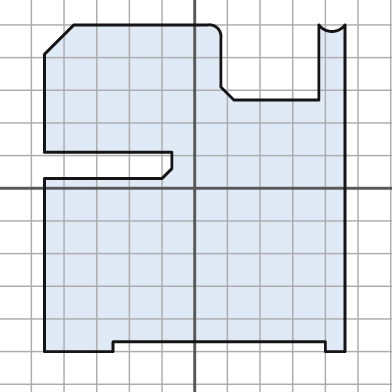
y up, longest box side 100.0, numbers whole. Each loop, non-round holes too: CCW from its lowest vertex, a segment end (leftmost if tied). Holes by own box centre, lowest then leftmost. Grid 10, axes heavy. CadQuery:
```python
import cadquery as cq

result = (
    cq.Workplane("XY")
    .moveTo(-46.0, -50.0)
    .lineTo(-25.0, -50.0)
    .lineTo(-25.0, -47.0)
    .lineTo(40.0, -47.0)
    .lineTo(40.0, -50.0)
    .lineTo(46.0, -50.0)
    .lineTo(46.0, 50.0)
    .threePointArc((42.0, 48.0), (38.0, 50.0))
    .lineTo(38.0, 27.0)
    .lineTo(12.0, 27.0)
    .lineTo(8.0, 31.0)
    .lineTo(8.0, 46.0)
    .threePointArc((7.0, 49.0), (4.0, 50.0))
    .lineTo(-37.0, 50.0)
    .lineTo(-46.0, 41.0)
    .lineTo(-46.0, 11.0)
    .lineTo(-7.0, 11.0)
    .lineTo(-7.0, 6.0)
    .lineTo(-10.0, 3.0)
    .lineTo(-46.0, 3.0)
    .close()
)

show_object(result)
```